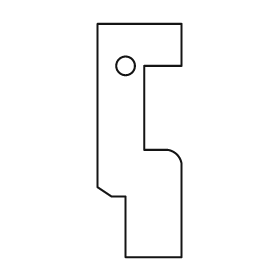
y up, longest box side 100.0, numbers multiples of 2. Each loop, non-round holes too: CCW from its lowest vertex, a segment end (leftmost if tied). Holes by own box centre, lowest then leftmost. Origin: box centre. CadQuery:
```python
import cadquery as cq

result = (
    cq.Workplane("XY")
    .moveTo(-6.0, -50.0)
    .lineTo(18.0, -50.0)
    .lineTo(18.0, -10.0)
    .threePointArc((16.0, -6.0), (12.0, -4.0))
    .lineTo(2.0, -4.0)
    .lineTo(2.0, 32.0)
    .lineTo(18.0, 32.0)
    .lineTo(18.0, 50.0)
    .lineTo(-18.0, 50.0)
    .lineTo(-18.0, -20.0)
    .lineTo(-12.0, -24.0)
    .lineTo(-6.0, -24.0)
    .close()
    .moveTo(-6.0, 32.0)
    .circle(4.0)
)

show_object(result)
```